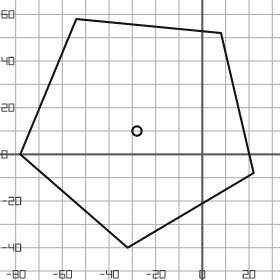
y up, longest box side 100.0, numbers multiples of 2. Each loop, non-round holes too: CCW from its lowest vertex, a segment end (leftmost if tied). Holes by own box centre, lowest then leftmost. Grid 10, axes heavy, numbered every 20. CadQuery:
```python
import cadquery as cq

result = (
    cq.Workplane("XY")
    .moveTo(-32.0, -40.0)
    .lineTo(22.0, -8.0)
    .lineTo(8.0, 52.0)
    .lineTo(-54.0, 58.0)
    .lineTo(-78.0, 0.0)
    .close()
    .moveTo(-28.0, 10.0)
    .circle(2.0)
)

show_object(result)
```